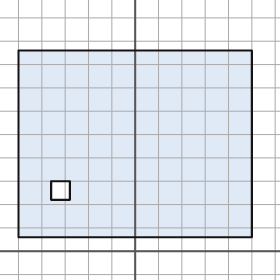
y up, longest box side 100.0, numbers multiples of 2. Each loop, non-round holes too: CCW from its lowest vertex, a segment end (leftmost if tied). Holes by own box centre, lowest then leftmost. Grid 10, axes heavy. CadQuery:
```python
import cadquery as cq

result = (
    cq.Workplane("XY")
    .moveTo(-50.0, 6.0)
    .lineTo(50.0, 6.0)
    .lineTo(50.0, 86.0)
    .lineTo(-50.0, 86.0)
    .close()
    .moveTo(-36.0, 22.0)
    .lineTo(-28.0, 22.0)
    .lineTo(-28.0, 30.0)
    .lineTo(-36.0, 30.0)
    .close()
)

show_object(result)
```